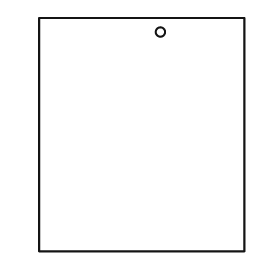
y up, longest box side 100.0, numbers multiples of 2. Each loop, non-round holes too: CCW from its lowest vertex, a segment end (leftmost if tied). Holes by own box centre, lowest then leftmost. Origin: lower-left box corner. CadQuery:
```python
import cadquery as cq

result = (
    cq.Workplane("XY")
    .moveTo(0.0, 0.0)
    .lineTo(88.0, 0.0)
    .lineTo(88.0, 100.0)
    .lineTo(0.0, 100.0)
    .close()
    .moveTo(52.0, 94.0)
    .circle(2.0)
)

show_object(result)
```